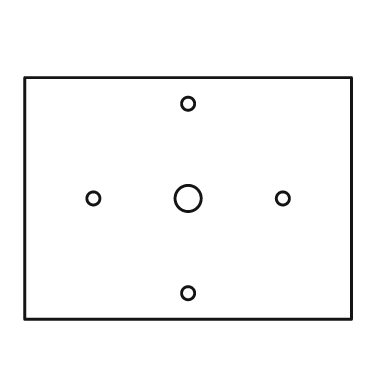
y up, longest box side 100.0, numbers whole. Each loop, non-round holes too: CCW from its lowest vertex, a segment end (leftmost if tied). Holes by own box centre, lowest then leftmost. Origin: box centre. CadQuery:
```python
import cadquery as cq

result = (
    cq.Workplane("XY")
    .moveTo(-50.0, -37.0)
    .lineTo(50.0, -37.0)
    .lineTo(50.0, 37.0)
    .lineTo(-50.0, 37.0)
    .close()
    .moveTo(0.0, -29.0)
    .circle(2.0)
    .moveTo(-29.0, 0.0)
    .circle(2.0)
    .moveTo(0.0, 0.0)
    .circle(4.0)
    .moveTo(29.0, 0.0)
    .circle(2.0)
    .moveTo(0.0, 29.0)
    .circle(2.0)
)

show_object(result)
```